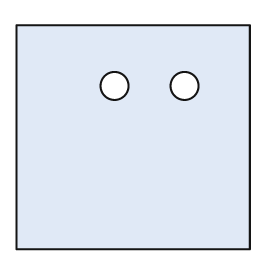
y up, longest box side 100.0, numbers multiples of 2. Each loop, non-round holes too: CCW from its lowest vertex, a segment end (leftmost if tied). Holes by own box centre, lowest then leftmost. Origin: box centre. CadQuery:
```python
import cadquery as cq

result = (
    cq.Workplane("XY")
    .moveTo(-50.0, -48.0)
    .lineTo(50.0, -48.0)
    .lineTo(50.0, 48.0)
    .lineTo(-50.0, 48.0)
    .close()
    .moveTo(-8.0, 22.0)
    .circle(6.0)
    .moveTo(22.0, 22.0)
    .circle(6.0)
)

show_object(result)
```